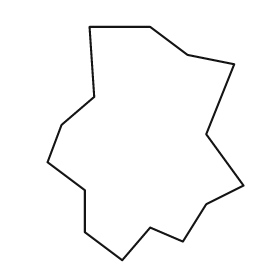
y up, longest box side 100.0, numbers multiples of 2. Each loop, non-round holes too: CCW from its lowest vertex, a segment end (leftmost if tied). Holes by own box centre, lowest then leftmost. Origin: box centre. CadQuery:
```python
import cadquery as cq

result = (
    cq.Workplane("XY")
    .moveTo(-10.0, -50.0)
    .lineTo(2.0, -36.0)
    .lineTo(16.0, -42.0)
    .lineTo(26.0, -26.0)
    .lineTo(42.0, -18.0)
    .lineTo(26.0, 4.0)
    .lineTo(38.0, 34.0)
    .lineTo(18.0, 38.0)
    .lineTo(2.0, 50.0)
    .lineTo(-24.0, 50.0)
    .lineTo(-22.0, 20.0)
    .lineTo(-36.0, 8.0)
    .lineTo(-42.0, -8.0)
    .lineTo(-26.0, -20.0)
    .lineTo(-26.0, -38.0)
    .close()
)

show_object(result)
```